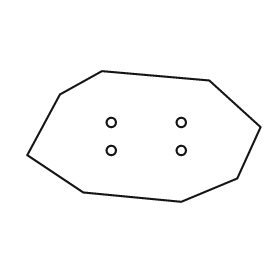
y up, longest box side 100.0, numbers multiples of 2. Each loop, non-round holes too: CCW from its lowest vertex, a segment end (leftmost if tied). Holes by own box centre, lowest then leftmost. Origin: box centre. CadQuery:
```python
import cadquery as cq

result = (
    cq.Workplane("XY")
    .moveTo(16.0, -28.0)
    .lineTo(40.0, -18.0)
    .lineTo(50.0, 4.0)
    .lineTo(28.0, 24.0)
    .lineTo(-18.0, 28.0)
    .lineTo(-36.0, 18.0)
    .lineTo(-50.0, -8.0)
    .lineTo(-26.0, -24.0)
    .close()
    .moveTo(-14.0, -6.0)
    .circle(2.0)
    .moveTo(16.0, -6.0)
    .circle(2.0)
    .moveTo(-14.0, 6.0)
    .circle(2.0)
    .moveTo(16.0, 6.0)
    .circle(2.0)
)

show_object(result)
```